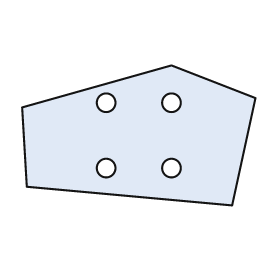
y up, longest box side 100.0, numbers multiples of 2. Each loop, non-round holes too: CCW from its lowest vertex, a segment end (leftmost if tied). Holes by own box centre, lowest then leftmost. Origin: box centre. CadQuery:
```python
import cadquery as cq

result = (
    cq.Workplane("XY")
    .moveTo(40.0, -30.0)
    .lineTo(50.0, 16.0)
    .lineTo(14.0, 30.0)
    .lineTo(-50.0, 12.0)
    .lineTo(-48.0, -22.0)
    .close()
    .moveTo(-14.0, -14.0)
    .circle(4.0)
    .moveTo(14.0, -14.0)
    .circle(4.0)
    .moveTo(-14.0, 14.0)
    .circle(4.0)
    .moveTo(14.0, 14.0)
    .circle(4.0)
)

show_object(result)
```